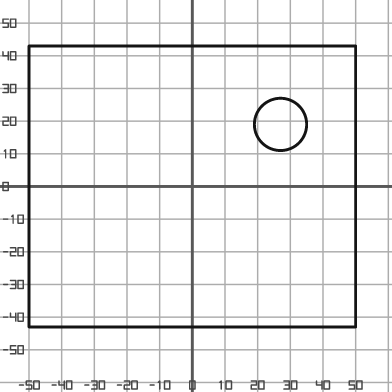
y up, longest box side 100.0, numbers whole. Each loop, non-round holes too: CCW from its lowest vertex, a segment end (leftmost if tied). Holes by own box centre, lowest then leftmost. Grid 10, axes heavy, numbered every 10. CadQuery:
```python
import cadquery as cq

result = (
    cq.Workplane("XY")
    .moveTo(-50.0, -43.0)
    .lineTo(50.0, -43.0)
    .lineTo(50.0, 43.0)
    .lineTo(-50.0, 43.0)
    .close()
    .moveTo(27.0, 19.0)
    .circle(8.0)
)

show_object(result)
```